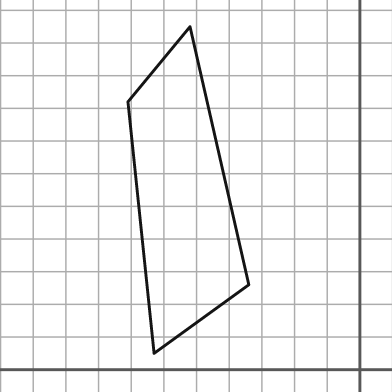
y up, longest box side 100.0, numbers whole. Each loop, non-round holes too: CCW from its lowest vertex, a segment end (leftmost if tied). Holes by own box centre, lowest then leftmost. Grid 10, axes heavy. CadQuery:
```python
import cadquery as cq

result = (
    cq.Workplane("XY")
    .moveTo(-63.0, 5.0)
    .lineTo(-34.0, 26.0)
    .lineTo(-52.0, 105.0)
    .lineTo(-71.0, 82.0)
    .close()
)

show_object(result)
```